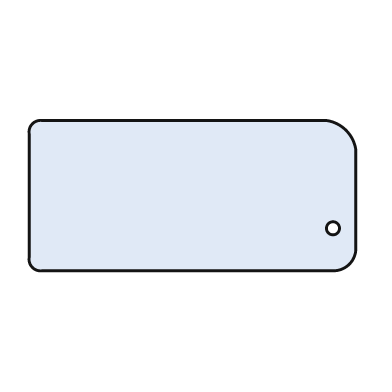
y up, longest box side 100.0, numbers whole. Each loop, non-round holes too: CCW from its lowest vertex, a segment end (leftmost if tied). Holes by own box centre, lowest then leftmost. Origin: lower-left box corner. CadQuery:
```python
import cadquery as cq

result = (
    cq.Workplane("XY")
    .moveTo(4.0, 0.0)
    .lineTo(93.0, 0.0)
    .threePointArc((98.0, 2.0), (100.0, 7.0))
    .lineTo(100.0, 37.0)
    .threePointArc((97.0, 43.0), (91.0, 46.0))
    .lineTo(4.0, 46.0)
    .threePointArc((1.0, 45.0), (0.0, 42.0))
    .lineTo(0.0, 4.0)
    .threePointArc((1.0, 1.0), (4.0, 0.0))
    .close()
    .moveTo(93.0, 13.0)
    .circle(2.0)
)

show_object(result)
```